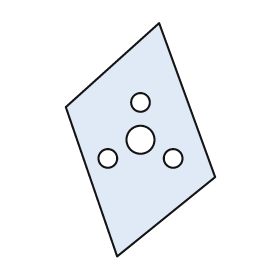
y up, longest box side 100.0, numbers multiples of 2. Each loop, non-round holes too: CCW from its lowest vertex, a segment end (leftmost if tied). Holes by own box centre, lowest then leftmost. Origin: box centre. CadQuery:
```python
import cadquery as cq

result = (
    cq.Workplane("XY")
    .moveTo(-10.0, -50.0)
    .lineTo(32.0, -16.0)
    .lineTo(8.0, 50.0)
    .lineTo(-32.0, 14.0)
    .close()
    .moveTo(-14.0, -8.0)
    .circle(4.0)
    .moveTo(14.0, -8.0)
    .circle(4.0)
    .moveTo(0.0, 0.0)
    .circle(6.0)
    .moveTo(0.0, 16.0)
    .circle(4.0)
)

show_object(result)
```